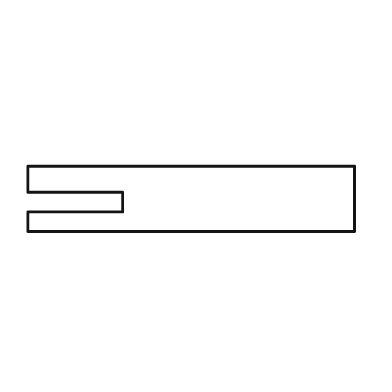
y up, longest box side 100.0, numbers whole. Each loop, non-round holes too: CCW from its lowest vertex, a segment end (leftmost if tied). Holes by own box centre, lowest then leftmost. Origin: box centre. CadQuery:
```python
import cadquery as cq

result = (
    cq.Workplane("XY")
    .moveTo(-50.0, -10.0)
    .lineTo(50.0, -10.0)
    .lineTo(50.0, 10.0)
    .lineTo(-50.0, 10.0)
    .lineTo(-50.0, 2.0)
    .lineTo(-21.0, 2.0)
    .lineTo(-21.0, -4.0)
    .lineTo(-50.0, -4.0)
    .close()
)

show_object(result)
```